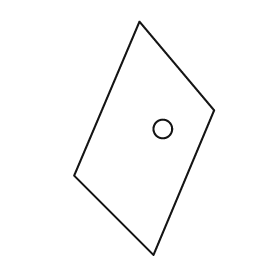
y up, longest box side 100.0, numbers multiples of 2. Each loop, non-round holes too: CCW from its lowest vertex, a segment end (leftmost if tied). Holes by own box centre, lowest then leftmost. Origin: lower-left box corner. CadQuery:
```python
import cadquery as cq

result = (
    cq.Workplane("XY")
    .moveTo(34.0, 0.0)
    .lineTo(60.0, 62.0)
    .lineTo(28.0, 100.0)
    .lineTo(0.0, 34.0)
    .close()
    .moveTo(38.0, 54.0)
    .circle(4.0)
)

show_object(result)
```